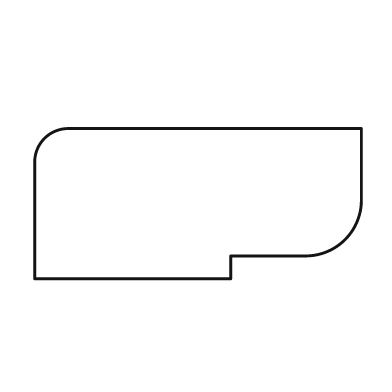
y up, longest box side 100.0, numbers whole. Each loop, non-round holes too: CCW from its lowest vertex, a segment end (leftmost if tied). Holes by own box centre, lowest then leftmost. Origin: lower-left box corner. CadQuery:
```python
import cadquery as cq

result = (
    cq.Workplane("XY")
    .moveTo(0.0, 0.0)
    .lineTo(60.0, 0.0)
    .lineTo(60.0, 7.0)
    .lineTo(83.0, 7.0)
    .threePointArc((95.0, 12.0), (100.0, 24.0))
    .lineTo(100.0, 46.0)
    .lineTo(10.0, 46.0)
    .threePointArc((3.0, 43.0), (0.0, 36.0))
    .close()
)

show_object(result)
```